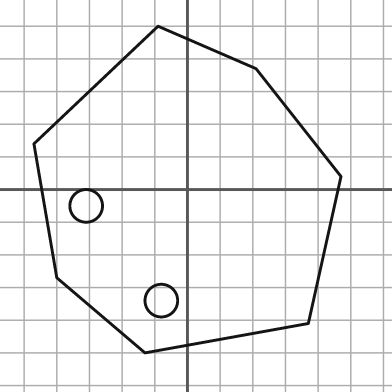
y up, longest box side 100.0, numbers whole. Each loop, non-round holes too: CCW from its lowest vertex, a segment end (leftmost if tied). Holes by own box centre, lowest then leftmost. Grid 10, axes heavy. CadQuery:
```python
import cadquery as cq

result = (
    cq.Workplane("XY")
    .moveTo(-13.0, -50.0)
    .lineTo(37.0, -41.0)
    .lineTo(47.0, 4.0)
    .lineTo(21.0, 37.0)
    .lineTo(-9.0, 50.0)
    .lineTo(-47.0, 14.0)
    .lineTo(-40.0, -27.0)
    .close()
    .moveTo(-8.0, -34.0)
    .circle(5.0)
    .moveTo(-31.0, -5.0)
    .circle(5.0)
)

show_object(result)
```